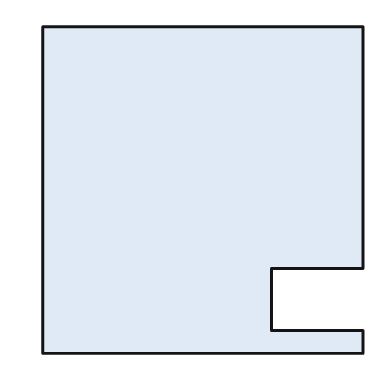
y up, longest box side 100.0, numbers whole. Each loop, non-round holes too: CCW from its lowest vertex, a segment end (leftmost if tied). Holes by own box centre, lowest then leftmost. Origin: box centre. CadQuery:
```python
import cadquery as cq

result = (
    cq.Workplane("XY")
    .moveTo(-49.0, -50.0)
    .lineTo(49.0, -50.0)
    .lineTo(49.0, -43.0)
    .lineTo(21.0, -43.0)
    .lineTo(21.0, -24.0)
    .lineTo(49.0, -24.0)
    .lineTo(49.0, 50.0)
    .lineTo(-49.0, 50.0)
    .close()
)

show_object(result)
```